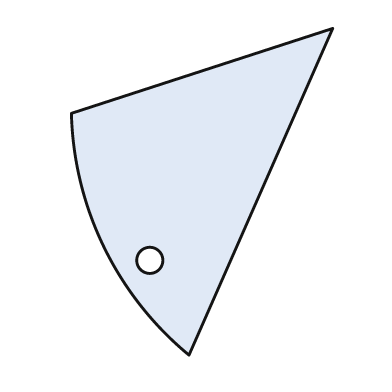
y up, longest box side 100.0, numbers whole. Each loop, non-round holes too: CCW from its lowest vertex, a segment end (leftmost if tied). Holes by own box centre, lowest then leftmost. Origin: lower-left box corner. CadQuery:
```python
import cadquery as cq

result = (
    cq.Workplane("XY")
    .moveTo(36.0, 0.0)
    .lineTo(80.0, 100.0)
    .lineTo(0.0, 74.0)
    .threePointArc((10.0, 33.0), (36.0, 0.0))
    .close()
    .moveTo(24.0, 29.0)
    .circle(4.0)
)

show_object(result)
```